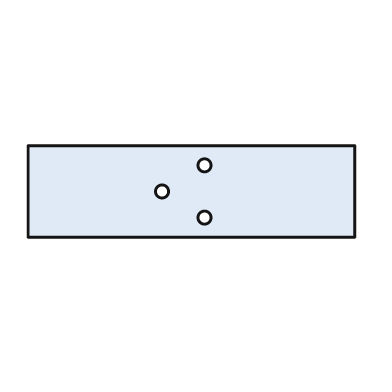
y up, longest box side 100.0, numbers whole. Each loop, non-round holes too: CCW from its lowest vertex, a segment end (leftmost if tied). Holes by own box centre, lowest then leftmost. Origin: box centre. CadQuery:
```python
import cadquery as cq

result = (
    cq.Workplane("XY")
    .moveTo(-50.0, -14.0)
    .lineTo(50.0, -14.0)
    .lineTo(50.0, 14.0)
    .lineTo(-50.0, 14.0)
    .close()
    .moveTo(4.0, -8.0)
    .circle(2.0)
    .moveTo(-9.0, 0.0)
    .circle(2.0)
    .moveTo(4.0, 8.0)
    .circle(2.0)
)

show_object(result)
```